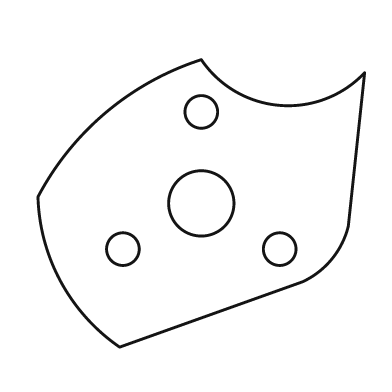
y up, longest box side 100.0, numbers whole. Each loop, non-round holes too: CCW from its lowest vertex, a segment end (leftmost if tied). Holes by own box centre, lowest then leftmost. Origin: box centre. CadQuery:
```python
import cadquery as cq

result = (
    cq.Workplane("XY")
    .moveTo(-25.0, -44.0)
    .lineTo(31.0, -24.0)
    .threePointArc((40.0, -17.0), (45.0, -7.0))
    .lineTo(50.0, 40.0)
    .threePointArc((24.0, 30.0), (0.0, 44.0))
    .threePointArc((-29.0, 28.0), (-50.0, 2.0))
    .threePointArc((-43.0, -24.0), (-25.0, -44.0))
    .close()
    .moveTo(-24.0, -14.0)
    .circle(5.0)
    .moveTo(24.0, -14.0)
    .circle(5.0)
    .moveTo(0.0, 0.0)
    .circle(10.0)
    .moveTo(0.0, 28.0)
    .circle(5.0)
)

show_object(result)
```